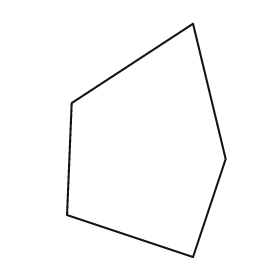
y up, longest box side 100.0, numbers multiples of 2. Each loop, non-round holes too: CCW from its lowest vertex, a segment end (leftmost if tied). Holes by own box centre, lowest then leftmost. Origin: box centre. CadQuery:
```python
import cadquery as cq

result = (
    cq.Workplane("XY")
    .moveTo(20.0, -50.0)
    .lineTo(34.0, -8.0)
    .lineTo(20.0, 50.0)
    .lineTo(-32.0, 16.0)
    .lineTo(-34.0, -32.0)
    .close()
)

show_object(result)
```